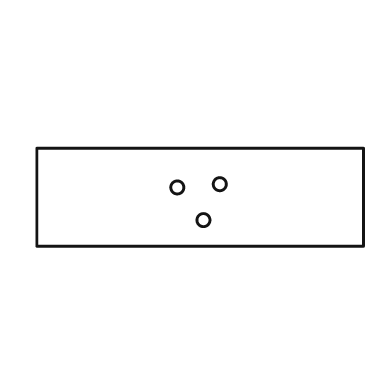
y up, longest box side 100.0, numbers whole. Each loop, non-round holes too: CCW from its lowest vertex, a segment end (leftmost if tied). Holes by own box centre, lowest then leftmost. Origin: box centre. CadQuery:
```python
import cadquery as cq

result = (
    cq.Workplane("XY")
    .moveTo(-50.0, -15.0)
    .lineTo(50.0, -15.0)
    .lineTo(50.0, 15.0)
    .lineTo(-50.0, 15.0)
    .close()
    .moveTo(1.0, -7.0)
    .circle(2.0)
    .moveTo(-7.0, 3.0)
    .circle(2.0)
    .moveTo(6.0, 4.0)
    .circle(2.0)
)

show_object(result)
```